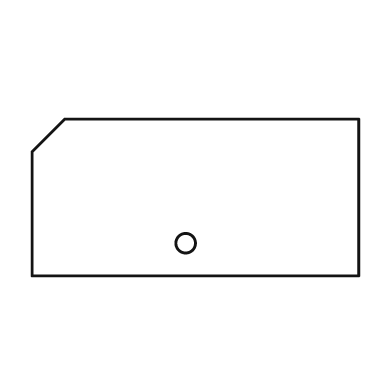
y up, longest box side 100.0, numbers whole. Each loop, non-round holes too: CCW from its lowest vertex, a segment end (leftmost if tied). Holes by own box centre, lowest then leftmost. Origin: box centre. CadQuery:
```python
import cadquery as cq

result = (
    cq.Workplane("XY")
    .moveTo(-50.0, -24.0)
    .lineTo(50.0, -24.0)
    .lineTo(50.0, 24.0)
    .lineTo(-40.0, 24.0)
    .lineTo(-50.0, 14.0)
    .close()
    .moveTo(-3.0, -14.0)
    .circle(3.0)
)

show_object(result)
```